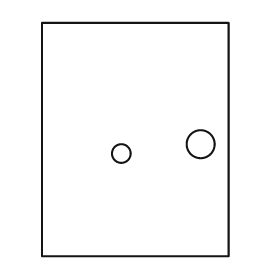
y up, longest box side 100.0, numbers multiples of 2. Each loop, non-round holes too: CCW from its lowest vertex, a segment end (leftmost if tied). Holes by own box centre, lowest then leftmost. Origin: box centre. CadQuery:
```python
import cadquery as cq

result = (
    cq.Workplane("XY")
    .moveTo(-40.0, -50.0)
    .lineTo(40.0, -50.0)
    .lineTo(40.0, 50.0)
    .lineTo(-40.0, 50.0)
    .close()
    .moveTo(-6.0, -6.0)
    .circle(4.0)
    .moveTo(28.0, -2.0)
    .circle(6.0)
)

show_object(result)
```